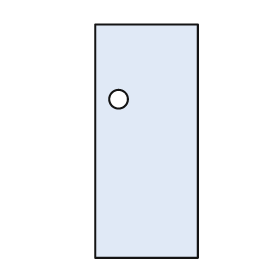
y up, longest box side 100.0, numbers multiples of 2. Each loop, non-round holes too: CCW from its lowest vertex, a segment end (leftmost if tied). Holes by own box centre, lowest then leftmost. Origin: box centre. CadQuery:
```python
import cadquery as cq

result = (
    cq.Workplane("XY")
    .moveTo(-22.0, -50.0)
    .lineTo(22.0, -50.0)
    .lineTo(22.0, 50.0)
    .lineTo(-22.0, 50.0)
    .close()
    .moveTo(-12.0, 18.0)
    .circle(4.0)
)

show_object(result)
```